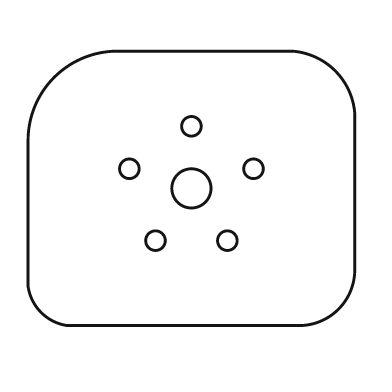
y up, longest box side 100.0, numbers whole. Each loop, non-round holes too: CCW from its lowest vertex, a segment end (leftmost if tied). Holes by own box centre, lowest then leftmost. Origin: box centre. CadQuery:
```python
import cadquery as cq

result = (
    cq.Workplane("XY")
    .moveTo(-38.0, -42.0)
    .lineTo(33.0, -42.0)
    .threePointArc((45.0, -37.0), (50.0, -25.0))
    .lineTo(50.0, 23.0)
    .threePointArc((44.0, 36.0), (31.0, 42.0))
    .lineTo(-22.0, 42.0)
    .threePointArc((-42.0, 34.0), (-50.0, 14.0))
    .lineTo(-50.0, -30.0)
    .threePointArc((-46.0, -38.0), (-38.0, -42.0))
    .close()
    .moveTo(-11.0, -16.0)
    .circle(3.0)
    .moveTo(11.0, -16.0)
    .circle(3.0)
    .moveTo(0.0, 0.0)
    .circle(6.0)
    .moveTo(-19.0, 6.0)
    .circle(3.0)
    .moveTo(19.0, 6.0)
    .circle(3.0)
    .moveTo(0.0, 19.0)
    .circle(3.0)
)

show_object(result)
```